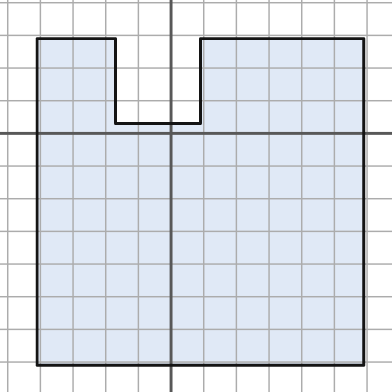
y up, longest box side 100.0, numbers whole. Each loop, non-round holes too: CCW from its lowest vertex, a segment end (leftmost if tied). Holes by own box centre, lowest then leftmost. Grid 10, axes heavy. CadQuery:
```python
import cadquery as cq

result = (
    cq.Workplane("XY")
    .moveTo(-41.0, -71.0)
    .lineTo(59.0, -71.0)
    .lineTo(59.0, 29.0)
    .lineTo(9.0, 29.0)
    .lineTo(9.0, 3.0)
    .lineTo(-17.0, 3.0)
    .lineTo(-17.0, 29.0)
    .lineTo(-41.0, 29.0)
    .close()
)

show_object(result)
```